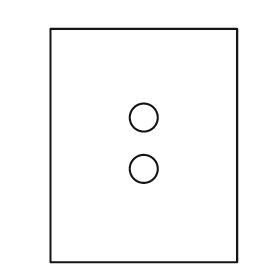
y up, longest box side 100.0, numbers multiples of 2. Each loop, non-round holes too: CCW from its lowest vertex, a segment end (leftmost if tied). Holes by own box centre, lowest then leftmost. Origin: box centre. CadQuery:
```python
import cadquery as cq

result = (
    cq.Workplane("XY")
    .moveTo(-40.0, -50.0)
    .lineTo(40.0, -50.0)
    .lineTo(40.0, 50.0)
    .lineTo(-40.0, 50.0)
    .close()
    .moveTo(0.0, -10.0)
    .circle(6.0)
    .moveTo(0.0, 12.0)
    .circle(6.0)
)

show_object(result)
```